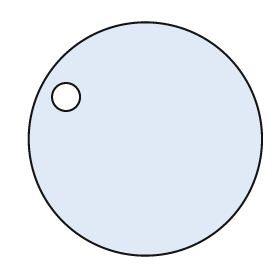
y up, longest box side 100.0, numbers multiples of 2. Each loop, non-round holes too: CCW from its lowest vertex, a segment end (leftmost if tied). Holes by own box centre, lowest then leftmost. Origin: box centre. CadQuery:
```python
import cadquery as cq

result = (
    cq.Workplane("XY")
    .moveTo(0.0, 0.0)
    .circle(50.0)
    .moveTo(-34.0, 18.0)
    .circle(6.0)
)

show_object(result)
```